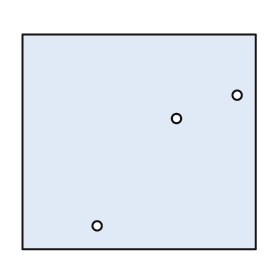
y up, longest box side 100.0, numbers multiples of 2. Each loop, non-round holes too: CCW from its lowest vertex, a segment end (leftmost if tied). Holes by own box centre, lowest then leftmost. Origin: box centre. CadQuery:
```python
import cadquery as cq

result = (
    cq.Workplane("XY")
    .moveTo(-50.0, -46.0)
    .lineTo(50.0, -46.0)
    .lineTo(50.0, 46.0)
    .lineTo(-50.0, 46.0)
    .close()
    .moveTo(-18.0, -36.0)
    .circle(2.0)
    .moveTo(16.0, 10.0)
    .circle(2.0)
    .moveTo(42.0, 20.0)
    .circle(2.0)
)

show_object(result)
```